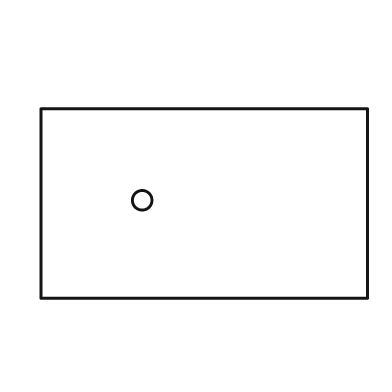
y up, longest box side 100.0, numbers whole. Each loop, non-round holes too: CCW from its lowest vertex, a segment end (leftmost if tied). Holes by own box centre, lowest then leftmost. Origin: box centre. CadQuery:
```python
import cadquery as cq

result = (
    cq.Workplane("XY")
    .moveTo(-50.0, -29.0)
    .lineTo(50.0, -29.0)
    .lineTo(50.0, 29.0)
    .lineTo(-50.0, 29.0)
    .close()
    .moveTo(-19.0, 1.0)
    .circle(3.0)
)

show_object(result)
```